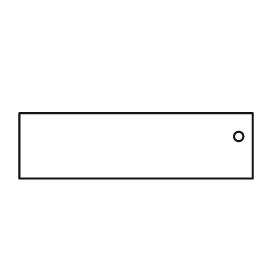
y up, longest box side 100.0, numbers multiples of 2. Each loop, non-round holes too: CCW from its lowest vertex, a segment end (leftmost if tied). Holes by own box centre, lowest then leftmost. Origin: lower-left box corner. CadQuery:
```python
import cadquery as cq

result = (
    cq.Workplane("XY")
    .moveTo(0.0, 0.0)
    .lineTo(100.0, 0.0)
    .lineTo(100.0, 28.0)
    .lineTo(0.0, 28.0)
    .close()
    .moveTo(94.0, 18.0)
    .circle(2.0)
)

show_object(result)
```